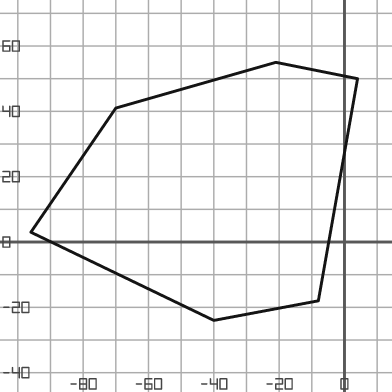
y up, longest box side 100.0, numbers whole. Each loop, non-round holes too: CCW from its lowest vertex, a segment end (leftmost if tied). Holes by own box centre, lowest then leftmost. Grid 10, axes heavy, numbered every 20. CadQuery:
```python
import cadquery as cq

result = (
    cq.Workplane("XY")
    .moveTo(-40.0, -24.0)
    .lineTo(-8.0, -18.0)
    .lineTo(4.0, 50.0)
    .lineTo(-21.0, 55.0)
    .lineTo(-70.0, 41.0)
    .lineTo(-96.0, 3.0)
    .close()
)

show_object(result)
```